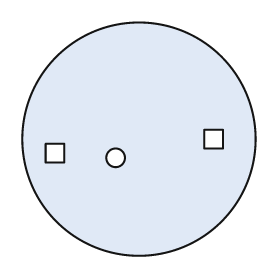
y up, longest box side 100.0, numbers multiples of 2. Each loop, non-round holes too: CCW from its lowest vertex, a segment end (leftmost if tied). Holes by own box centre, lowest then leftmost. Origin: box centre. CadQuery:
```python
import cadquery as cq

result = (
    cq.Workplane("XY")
    .moveTo(0.0, 0.0)
    .circle(50.0)
    .moveTo(-10.0, -8.0)
    .circle(4.0)
    .moveTo(-40.0, -10.0)
    .lineTo(-32.0, -10.0)
    .lineTo(-32.0, -2.0)
    .lineTo(-40.0, -2.0)
    .close()
    .moveTo(28.0, -4.0)
    .lineTo(36.0, -4.0)
    .lineTo(36.0, 4.0)
    .lineTo(28.0, 4.0)
    .close()
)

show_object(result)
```